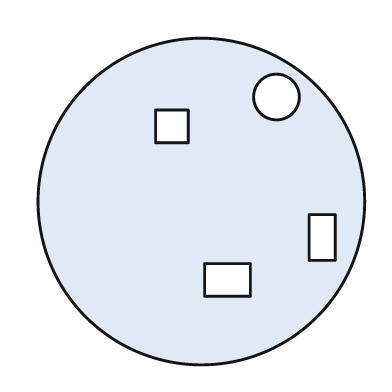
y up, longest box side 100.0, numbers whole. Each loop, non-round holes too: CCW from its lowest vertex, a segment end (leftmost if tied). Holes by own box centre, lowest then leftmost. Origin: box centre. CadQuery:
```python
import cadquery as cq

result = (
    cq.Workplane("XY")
    .moveTo(0.0, 0.0)
    .circle(50.0)
    .moveTo(1.0, -29.0)
    .lineTo(15.0, -29.0)
    .lineTo(15.0, -19.0)
    .lineTo(1.0, -19.0)
    .close()
    .moveTo(33.0, -18.0)
    .lineTo(41.0, -18.0)
    .lineTo(41.0, -4.0)
    .lineTo(33.0, -4.0)
    .close()
    .moveTo(-14.0, 18.0)
    .lineTo(-4.0, 18.0)
    .lineTo(-4.0, 28.0)
    .lineTo(-14.0, 28.0)
    .close()
    .moveTo(23.0, 32.0)
    .circle(7.0)
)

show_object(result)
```